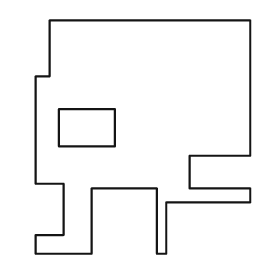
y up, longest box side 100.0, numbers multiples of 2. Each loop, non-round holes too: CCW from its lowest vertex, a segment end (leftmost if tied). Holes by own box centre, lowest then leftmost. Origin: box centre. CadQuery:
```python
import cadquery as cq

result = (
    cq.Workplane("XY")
    .moveTo(-46.0, -50.0)
    .lineTo(-22.0, -50.0)
    .lineTo(-22.0, -22.0)
    .lineTo(6.0, -22.0)
    .lineTo(6.0, -50.0)
    .lineTo(10.0, -50.0)
    .lineTo(10.0, -28.0)
    .lineTo(46.0, -28.0)
    .lineTo(46.0, -22.0)
    .lineTo(20.0, -22.0)
    .lineTo(20.0, -8.0)
    .lineTo(46.0, -8.0)
    .lineTo(46.0, 50.0)
    .lineTo(-40.0, 50.0)
    .lineTo(-40.0, 26.0)
    .lineTo(-46.0, 26.0)
    .lineTo(-46.0, -20.0)
    .lineTo(-34.0, -20.0)
    .lineTo(-34.0, -42.0)
    .lineTo(-46.0, -42.0)
    .close()
    .moveTo(-36.0, -4.0)
    .lineTo(-12.0, -4.0)
    .lineTo(-12.0, 12.0)
    .lineTo(-36.0, 12.0)
    .close()
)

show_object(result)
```